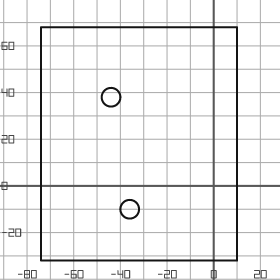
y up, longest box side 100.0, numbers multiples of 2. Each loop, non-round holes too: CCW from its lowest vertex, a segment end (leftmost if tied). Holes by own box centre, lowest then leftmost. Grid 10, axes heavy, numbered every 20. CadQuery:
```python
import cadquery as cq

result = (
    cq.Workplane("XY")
    .moveTo(-74.0, -32.0)
    .lineTo(10.0, -32.0)
    .lineTo(10.0, 68.0)
    .lineTo(-74.0, 68.0)
    .close()
    .moveTo(-36.0, -10.0)
    .circle(4.0)
    .moveTo(-44.0, 38.0)
    .circle(4.0)
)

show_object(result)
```